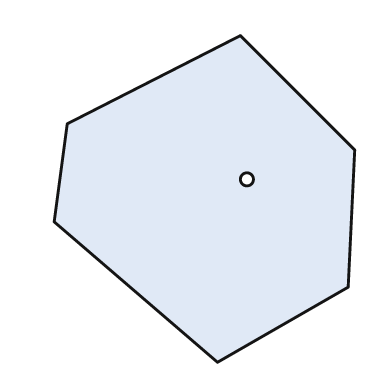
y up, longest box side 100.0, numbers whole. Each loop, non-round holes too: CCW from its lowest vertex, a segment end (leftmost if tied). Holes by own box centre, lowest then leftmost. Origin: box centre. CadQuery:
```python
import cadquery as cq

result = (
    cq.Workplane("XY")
    .moveTo(4.0, -50.0)
    .lineTo(44.0, -27.0)
    .lineTo(46.0, 15.0)
    .lineTo(11.0, 50.0)
    .lineTo(-42.0, 23.0)
    .lineTo(-46.0, -7.0)
    .close()
    .moveTo(13.0, 6.0)
    .circle(2.0)
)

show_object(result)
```